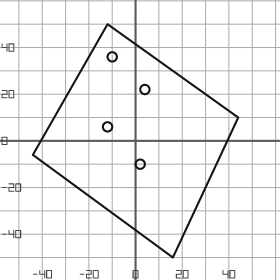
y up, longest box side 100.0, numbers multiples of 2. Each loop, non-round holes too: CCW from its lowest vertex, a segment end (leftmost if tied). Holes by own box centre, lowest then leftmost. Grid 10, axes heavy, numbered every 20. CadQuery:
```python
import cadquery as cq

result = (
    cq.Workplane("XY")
    .moveTo(16.0, -50.0)
    .lineTo(44.0, 10.0)
    .lineTo(-12.0, 50.0)
    .lineTo(-44.0, -6.0)
    .close()
    .moveTo(2.0, -10.0)
    .circle(2.0)
    .moveTo(-12.0, 6.0)
    .circle(2.0)
    .moveTo(4.0, 22.0)
    .circle(2.0)
    .moveTo(-10.0, 36.0)
    .circle(2.0)
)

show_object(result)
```